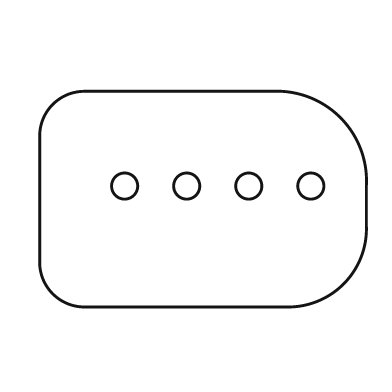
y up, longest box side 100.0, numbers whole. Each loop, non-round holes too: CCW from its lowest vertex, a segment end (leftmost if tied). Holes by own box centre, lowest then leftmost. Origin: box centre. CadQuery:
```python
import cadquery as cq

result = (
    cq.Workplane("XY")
    .moveTo(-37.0, -33.0)
    .lineTo(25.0, -33.0)
    .threePointArc((43.0, -26.0), (50.0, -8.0))
    .lineTo(50.0, 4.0)
    .threePointArc((42.0, 25.0), (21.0, 33.0))
    .lineTo(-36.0, 33.0)
    .threePointArc((-46.0, 29.0), (-50.0, 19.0))
    .lineTo(-50.0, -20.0)
    .threePointArc((-46.0, -29.0), (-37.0, -33.0))
    .close()
    .moveTo(-24.0, 4.0)
    .circle(4.0)
    .moveTo(-5.0, 4.0)
    .circle(4.0)
    .moveTo(14.0, 4.0)
    .circle(4.0)
    .moveTo(33.0, 4.0)
    .circle(4.0)
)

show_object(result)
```